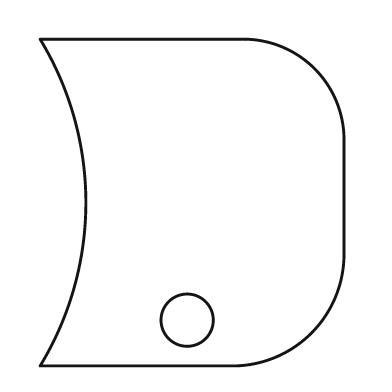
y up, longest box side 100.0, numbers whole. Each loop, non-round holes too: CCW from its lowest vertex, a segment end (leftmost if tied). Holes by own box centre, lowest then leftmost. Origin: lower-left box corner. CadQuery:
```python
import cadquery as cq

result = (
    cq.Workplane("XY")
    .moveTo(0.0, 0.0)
    .lineTo(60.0, 0.0)
    .threePointArc((83.0, 10.0), (93.0, 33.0))
    .lineTo(93.0, 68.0)
    .threePointArc((84.0, 91.0), (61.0, 100.0))
    .lineTo(0.0, 100.0)
    .threePointArc((14.0, 50.0), (0.0, 0.0))
    .close()
    .moveTo(45.0, 14.0)
    .circle(8.0)
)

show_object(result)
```